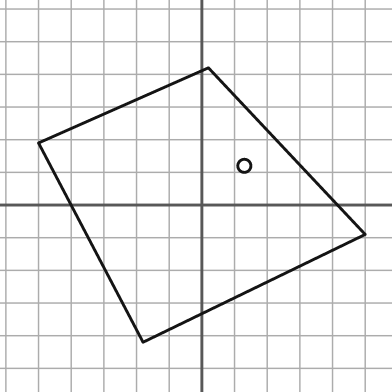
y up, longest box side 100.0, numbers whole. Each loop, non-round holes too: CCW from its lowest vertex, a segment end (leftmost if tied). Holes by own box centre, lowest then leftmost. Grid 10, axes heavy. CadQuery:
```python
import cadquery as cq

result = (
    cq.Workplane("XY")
    .moveTo(-18.0, -42.0)
    .lineTo(50.0, -9.0)
    .lineTo(2.0, 42.0)
    .lineTo(-50.0, 19.0)
    .close()
    .moveTo(13.0, 12.0)
    .circle(2.0)
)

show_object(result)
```